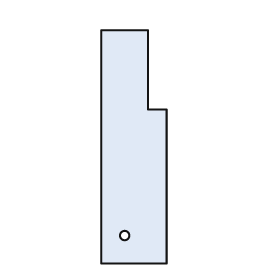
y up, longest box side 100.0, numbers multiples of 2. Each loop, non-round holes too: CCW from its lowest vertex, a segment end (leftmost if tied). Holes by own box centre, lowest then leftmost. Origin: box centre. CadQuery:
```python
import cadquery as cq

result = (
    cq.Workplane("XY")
    .moveTo(-14.0, -50.0)
    .lineTo(14.0, -50.0)
    .lineTo(14.0, 16.0)
    .lineTo(6.0, 16.0)
    .lineTo(6.0, 50.0)
    .lineTo(-14.0, 50.0)
    .close()
    .moveTo(-4.0, -38.0)
    .circle(2.0)
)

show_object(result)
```